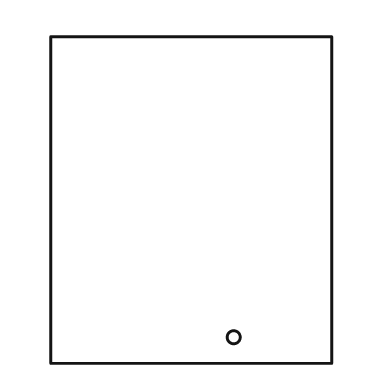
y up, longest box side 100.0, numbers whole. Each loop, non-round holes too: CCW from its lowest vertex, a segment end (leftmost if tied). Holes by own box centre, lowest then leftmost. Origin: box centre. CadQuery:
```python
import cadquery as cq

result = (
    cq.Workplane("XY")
    .moveTo(-43.0, -50.0)
    .lineTo(43.0, -50.0)
    .lineTo(43.0, 50.0)
    .lineTo(-43.0, 50.0)
    .close()
    .moveTo(13.0, -42.0)
    .circle(2.0)
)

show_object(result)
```